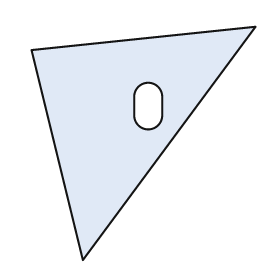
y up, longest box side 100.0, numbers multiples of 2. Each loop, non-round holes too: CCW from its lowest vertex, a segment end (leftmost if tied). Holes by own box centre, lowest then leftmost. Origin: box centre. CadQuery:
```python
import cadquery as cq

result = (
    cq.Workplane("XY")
    .moveTo(-26.0, -50.0)
    .lineTo(48.0, 50.0)
    .lineTo(-48.0, 40.0)
    .close()
    .moveTo(-4.0, 12.0)
    .threePointArc((2.0, 6.0), (8.0, 12.0))
    .lineTo(8.0, 20.0)
    .threePointArc((2.0, 26.0), (-4.0, 20.0))
    .close()
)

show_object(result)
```